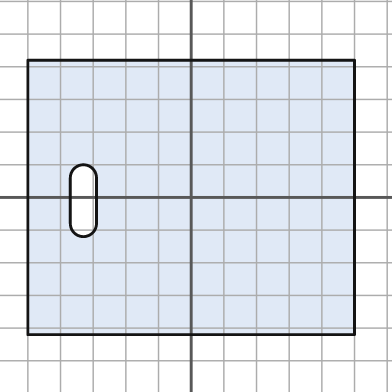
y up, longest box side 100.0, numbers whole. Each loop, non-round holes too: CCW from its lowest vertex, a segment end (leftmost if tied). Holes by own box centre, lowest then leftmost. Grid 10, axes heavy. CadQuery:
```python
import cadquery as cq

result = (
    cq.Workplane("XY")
    .moveTo(-50.0, -42.0)
    .lineTo(50.0, -42.0)
    .lineTo(50.0, 42.0)
    .lineTo(-50.0, 42.0)
    .close()
    .moveTo(-37.0, -8.0)
    .threePointArc((-33.0, -12.0), (-29.0, -8.0))
    .lineTo(-29.0, 6.0)
    .threePointArc((-33.0, 10.0), (-37.0, 6.0))
    .close()
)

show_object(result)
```